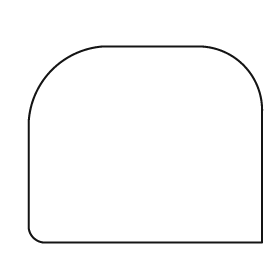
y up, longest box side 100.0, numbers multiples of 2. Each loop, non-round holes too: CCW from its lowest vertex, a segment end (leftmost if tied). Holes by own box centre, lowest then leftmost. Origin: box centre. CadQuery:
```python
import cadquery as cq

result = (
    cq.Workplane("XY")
    .moveTo(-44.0, -42.0)
    .lineTo(50.0, -42.0)
    .lineTo(50.0, 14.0)
    .threePointArc((42.0, 34.0), (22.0, 42.0))
    .lineTo(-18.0, 42.0)
    .threePointArc((-40.0, 32.0), (-50.0, 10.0))
    .lineTo(-50.0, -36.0)
    .threePointArc((-48.0, -40.0), (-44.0, -42.0))
    .close()
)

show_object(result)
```